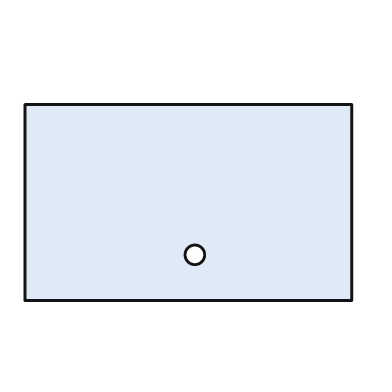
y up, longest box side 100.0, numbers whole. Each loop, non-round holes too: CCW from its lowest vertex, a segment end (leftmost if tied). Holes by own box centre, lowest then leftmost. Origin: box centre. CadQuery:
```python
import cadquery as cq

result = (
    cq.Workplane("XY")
    .moveTo(-50.0, -30.0)
    .lineTo(50.0, -30.0)
    .lineTo(50.0, 30.0)
    .lineTo(-50.0, 30.0)
    .close()
    .moveTo(2.0, -16.0)
    .circle(3.0)
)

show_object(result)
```